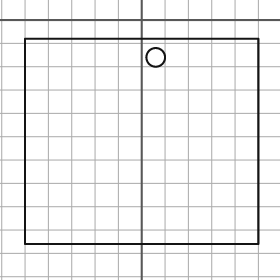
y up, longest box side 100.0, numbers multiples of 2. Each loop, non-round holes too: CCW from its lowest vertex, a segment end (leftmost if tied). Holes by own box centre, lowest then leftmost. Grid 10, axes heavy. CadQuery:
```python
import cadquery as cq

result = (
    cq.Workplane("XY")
    .moveTo(-50.0, -96.0)
    .lineTo(50.0, -96.0)
    .lineTo(50.0, -8.0)
    .lineTo(-50.0, -8.0)
    .close()
    .moveTo(6.0, -16.0)
    .circle(4.0)
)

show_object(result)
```